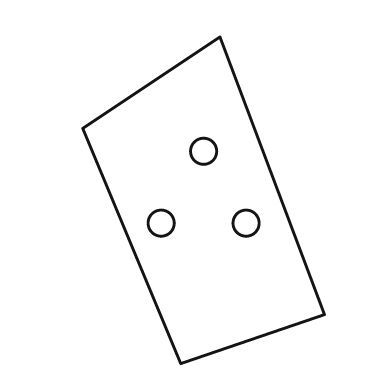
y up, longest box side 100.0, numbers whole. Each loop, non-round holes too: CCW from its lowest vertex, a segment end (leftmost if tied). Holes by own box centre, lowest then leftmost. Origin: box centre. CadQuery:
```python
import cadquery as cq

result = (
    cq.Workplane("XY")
    .moveTo(-7.0, -50.0)
    .lineTo(37.0, -35.0)
    .lineTo(5.0, 50.0)
    .lineTo(-37.0, 22.0)
    .close()
    .moveTo(-13.0, -7.0)
    .circle(4.0)
    .moveTo(13.0, -7.0)
    .circle(4.0)
    .moveTo(0.0, 15.0)
    .circle(4.0)
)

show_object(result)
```